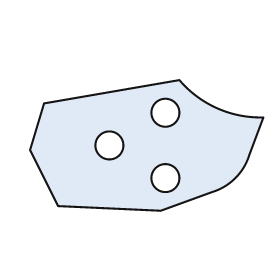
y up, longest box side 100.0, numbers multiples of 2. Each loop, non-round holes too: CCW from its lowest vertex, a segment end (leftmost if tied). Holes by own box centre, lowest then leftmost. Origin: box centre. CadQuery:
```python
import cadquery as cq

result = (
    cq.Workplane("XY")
    .moveTo(6.0, -28.0)
    .lineTo(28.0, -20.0)
    .threePointArc((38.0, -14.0), (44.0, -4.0))
    .lineTo(50.0, 12.0)
    .threePointArc((30.0, 16.0), (14.0, 28.0))
    .lineTo(-44.0, 18.0)
    .lineTo(-50.0, -2.0)
    .lineTo(-38.0, -26.0)
    .close()
    .moveTo(8.0, -14.0)
    .circle(6.0)
    .moveTo(-16.0, 0.0)
    .circle(6.0)
    .moveTo(8.0, 14.0)
    .circle(6.0)
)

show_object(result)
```